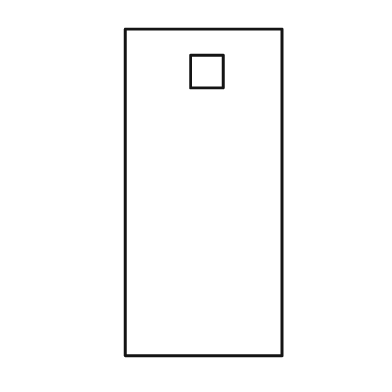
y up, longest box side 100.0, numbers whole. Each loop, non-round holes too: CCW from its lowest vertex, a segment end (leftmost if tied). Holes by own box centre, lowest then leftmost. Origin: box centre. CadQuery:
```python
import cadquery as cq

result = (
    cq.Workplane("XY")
    .moveTo(-24.0, -50.0)
    .lineTo(24.0, -50.0)
    .lineTo(24.0, 50.0)
    .lineTo(-24.0, 50.0)
    .close()
    .moveTo(-4.0, 32.0)
    .lineTo(6.0, 32.0)
    .lineTo(6.0, 42.0)
    .lineTo(-4.0, 42.0)
    .close()
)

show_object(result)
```